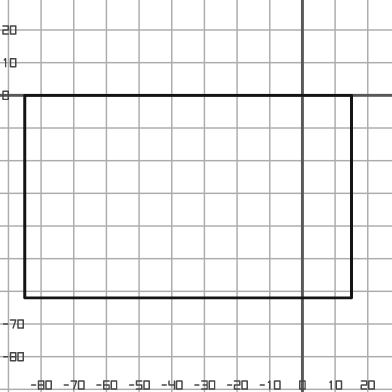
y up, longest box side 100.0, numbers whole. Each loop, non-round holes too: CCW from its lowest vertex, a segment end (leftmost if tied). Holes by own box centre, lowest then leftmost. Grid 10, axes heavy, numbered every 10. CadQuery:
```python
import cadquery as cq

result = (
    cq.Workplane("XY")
    .moveTo(-85.0, -62.0)
    .lineTo(15.0, -62.0)
    .lineTo(15.0, 0.0)
    .lineTo(-85.0, 0.0)
    .close()
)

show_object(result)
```